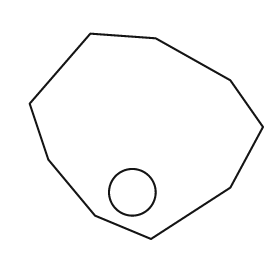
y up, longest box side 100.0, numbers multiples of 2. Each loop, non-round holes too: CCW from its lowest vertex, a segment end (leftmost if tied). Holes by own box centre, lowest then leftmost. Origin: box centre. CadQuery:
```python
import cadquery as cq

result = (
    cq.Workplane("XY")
    .moveTo(2.0, -44.0)
    .lineTo(36.0, -22.0)
    .lineTo(50.0, 4.0)
    .lineTo(36.0, 24.0)
    .lineTo(4.0, 42.0)
    .lineTo(-24.0, 44.0)
    .lineTo(-50.0, 14.0)
    .lineTo(-42.0, -10.0)
    .lineTo(-22.0, -34.0)
    .close()
    .moveTo(-6.0, -24.0)
    .circle(10.0)
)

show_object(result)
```